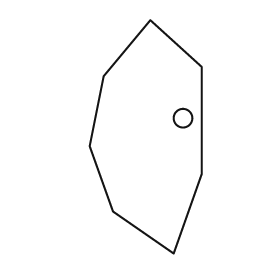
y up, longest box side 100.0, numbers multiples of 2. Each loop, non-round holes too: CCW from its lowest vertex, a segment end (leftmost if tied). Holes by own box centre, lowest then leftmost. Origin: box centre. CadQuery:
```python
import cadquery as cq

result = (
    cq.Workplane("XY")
    .moveTo(12.0, -50.0)
    .lineTo(24.0, -16.0)
    .lineTo(24.0, 30.0)
    .lineTo(2.0, 50.0)
    .lineTo(-18.0, 26.0)
    .lineTo(-24.0, -4.0)
    .lineTo(-14.0, -32.0)
    .close()
    .moveTo(16.0, 8.0)
    .circle(4.0)
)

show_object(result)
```